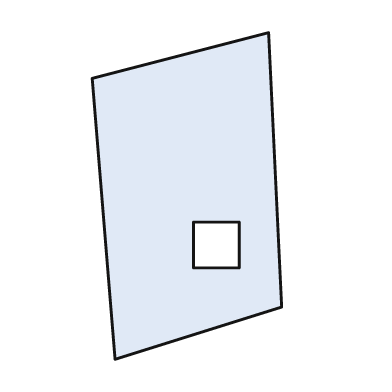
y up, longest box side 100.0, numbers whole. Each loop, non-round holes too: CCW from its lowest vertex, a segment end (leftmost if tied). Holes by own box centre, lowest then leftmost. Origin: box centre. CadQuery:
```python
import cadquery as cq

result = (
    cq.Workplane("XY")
    .moveTo(-22.0, -50.0)
    .lineTo(29.0, -34.0)
    .lineTo(25.0, 50.0)
    .lineTo(-29.0, 36.0)
    .close()
    .moveTo(2.0, -22.0)
    .lineTo(16.0, -22.0)
    .lineTo(16.0, -8.0)
    .lineTo(2.0, -8.0)
    .close()
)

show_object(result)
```